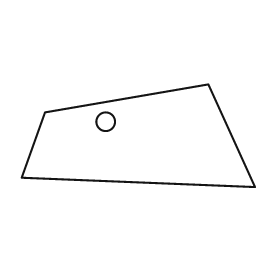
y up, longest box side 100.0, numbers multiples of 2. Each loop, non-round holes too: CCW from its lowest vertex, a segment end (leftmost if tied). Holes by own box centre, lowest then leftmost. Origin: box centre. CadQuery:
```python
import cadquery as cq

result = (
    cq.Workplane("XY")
    .moveTo(50.0, -22.0)
    .lineTo(30.0, 22.0)
    .lineTo(-40.0, 10.0)
    .lineTo(-50.0, -18.0)
    .close()
    .moveTo(-14.0, 6.0)
    .circle(4.0)
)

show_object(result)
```